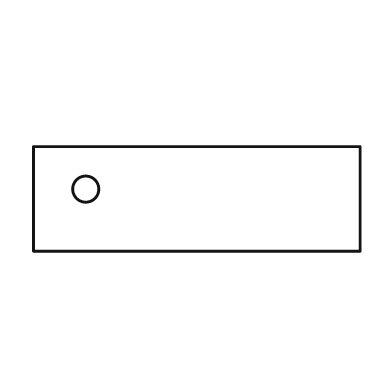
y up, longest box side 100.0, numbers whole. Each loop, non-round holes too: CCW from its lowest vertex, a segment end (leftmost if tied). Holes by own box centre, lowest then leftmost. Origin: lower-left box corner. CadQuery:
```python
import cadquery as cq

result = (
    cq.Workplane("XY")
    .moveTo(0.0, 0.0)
    .lineTo(100.0, 0.0)
    .lineTo(100.0, 32.0)
    .lineTo(0.0, 32.0)
    .close()
    .moveTo(16.0, 19.0)
    .circle(4.0)
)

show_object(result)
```